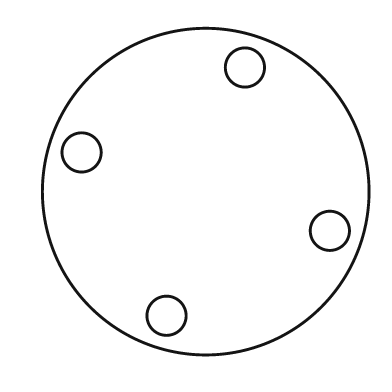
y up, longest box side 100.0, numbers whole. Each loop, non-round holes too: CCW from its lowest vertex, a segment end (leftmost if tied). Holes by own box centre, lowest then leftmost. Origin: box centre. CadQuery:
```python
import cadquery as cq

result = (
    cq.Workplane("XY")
    .moveTo(0.0, 0.0)
    .circle(50.0)
    .moveTo(-12.0, -38.0)
    .circle(6.0)
    .moveTo(38.0, -12.0)
    .circle(6.0)
    .moveTo(-38.0, 12.0)
    .circle(6.0)
    .moveTo(12.0, 38.0)
    .circle(6.0)
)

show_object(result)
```